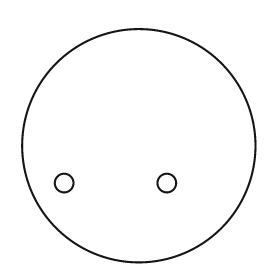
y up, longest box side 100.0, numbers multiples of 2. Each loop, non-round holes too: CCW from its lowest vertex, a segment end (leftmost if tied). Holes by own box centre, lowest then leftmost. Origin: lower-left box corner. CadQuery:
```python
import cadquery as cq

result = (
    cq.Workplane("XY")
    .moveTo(50.0, 50.0)
    .circle(50.0)
    .moveTo(18.0, 34.0)
    .circle(4.0)
    .moveTo(62.0, 34.0)
    .circle(4.0)
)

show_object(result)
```